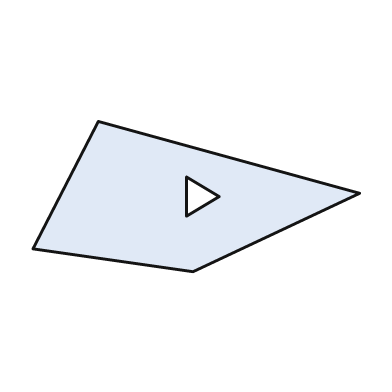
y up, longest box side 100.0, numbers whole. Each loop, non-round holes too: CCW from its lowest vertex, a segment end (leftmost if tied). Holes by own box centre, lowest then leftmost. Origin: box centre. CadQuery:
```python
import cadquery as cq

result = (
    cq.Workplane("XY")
    .moveTo(-1.0, -23.0)
    .lineTo(50.0, 1.0)
    .lineTo(-30.0, 23.0)
    .lineTo(-50.0, -16.0)
    .close()
    .moveTo(-3.0, -6.0)
    .lineTo(7.0, 0.0)
    .lineTo(-3.0, 6.0)
    .close()
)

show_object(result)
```